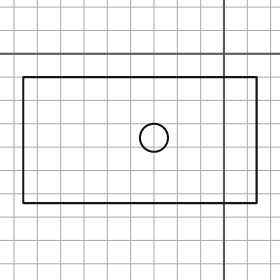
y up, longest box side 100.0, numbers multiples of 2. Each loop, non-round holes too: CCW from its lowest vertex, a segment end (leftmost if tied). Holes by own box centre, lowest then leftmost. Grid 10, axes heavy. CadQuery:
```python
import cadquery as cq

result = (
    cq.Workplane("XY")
    .moveTo(-86.0, -64.0)
    .lineTo(14.0, -64.0)
    .lineTo(14.0, -10.0)
    .lineTo(-86.0, -10.0)
    .close()
    .moveTo(-30.0, -36.0)
    .circle(6.0)
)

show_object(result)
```